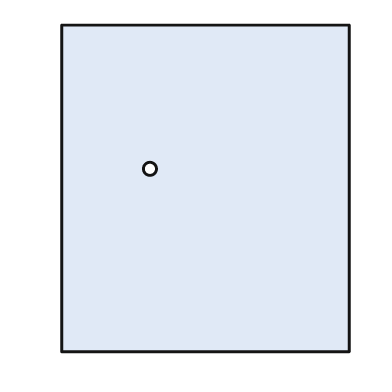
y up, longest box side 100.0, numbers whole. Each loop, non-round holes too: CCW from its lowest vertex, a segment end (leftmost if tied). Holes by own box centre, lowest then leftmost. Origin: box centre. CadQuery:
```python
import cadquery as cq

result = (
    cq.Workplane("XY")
    .moveTo(-44.0, -50.0)
    .lineTo(44.0, -50.0)
    .lineTo(44.0, 50.0)
    .lineTo(-44.0, 50.0)
    .close()
    .moveTo(-17.0, 6.0)
    .circle(2.0)
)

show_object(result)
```